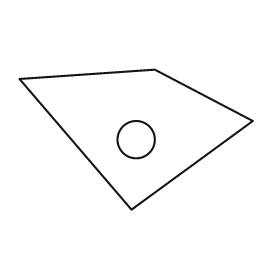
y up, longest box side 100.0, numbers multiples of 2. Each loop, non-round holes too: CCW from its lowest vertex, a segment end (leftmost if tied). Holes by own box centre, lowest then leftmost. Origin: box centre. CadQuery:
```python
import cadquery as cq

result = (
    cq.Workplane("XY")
    .moveTo(-2.0, -30.0)
    .lineTo(50.0, 8.0)
    .lineTo(8.0, 30.0)
    .lineTo(-50.0, 26.0)
    .close()
    .moveTo(0.0, 0.0)
    .circle(8.0)
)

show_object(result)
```